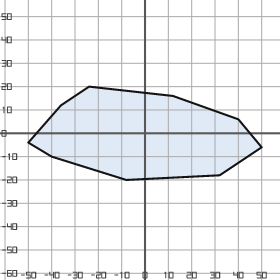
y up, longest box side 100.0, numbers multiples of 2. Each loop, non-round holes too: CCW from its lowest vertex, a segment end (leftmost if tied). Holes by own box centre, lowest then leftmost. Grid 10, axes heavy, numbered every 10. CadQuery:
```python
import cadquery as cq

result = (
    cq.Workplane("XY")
    .moveTo(-8.0, -20.0)
    .lineTo(32.0, -18.0)
    .lineTo(50.0, -6.0)
    .lineTo(40.0, 6.0)
    .lineTo(12.0, 16.0)
    .lineTo(-24.0, 20.0)
    .lineTo(-36.0, 12.0)
    .lineTo(-50.0, -4.0)
    .lineTo(-40.0, -10.0)
    .close()
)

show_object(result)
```